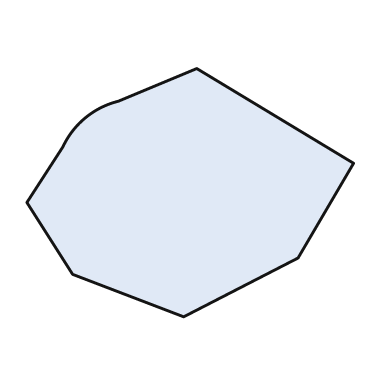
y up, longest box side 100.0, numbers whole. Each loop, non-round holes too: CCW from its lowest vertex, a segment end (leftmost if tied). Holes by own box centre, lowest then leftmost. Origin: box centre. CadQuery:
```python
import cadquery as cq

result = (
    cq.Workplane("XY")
    .moveTo(-2.0, -38.0)
    .lineTo(33.0, -20.0)
    .lineTo(50.0, 9.0)
    .lineTo(2.0, 38.0)
    .lineTo(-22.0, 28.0)
    .threePointArc((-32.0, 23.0), (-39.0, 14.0))
    .lineTo(-50.0, -3.0)
    .lineTo(-36.0, -25.0)
    .close()
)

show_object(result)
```